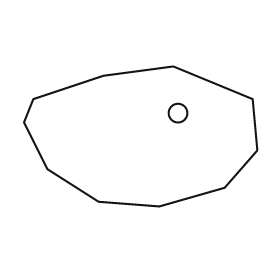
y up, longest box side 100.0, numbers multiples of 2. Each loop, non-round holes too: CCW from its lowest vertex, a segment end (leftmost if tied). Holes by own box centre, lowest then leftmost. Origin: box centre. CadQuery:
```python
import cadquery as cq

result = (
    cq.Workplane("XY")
    .moveTo(8.0, -30.0)
    .lineTo(36.0, -22.0)
    .lineTo(50.0, -6.0)
    .lineTo(48.0, 16.0)
    .lineTo(14.0, 30.0)
    .lineTo(-16.0, 26.0)
    .lineTo(-46.0, 16.0)
    .lineTo(-50.0, 6.0)
    .lineTo(-40.0, -14.0)
    .lineTo(-18.0, -28.0)
    .close()
    .moveTo(16.0, 10.0)
    .circle(4.0)
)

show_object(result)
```